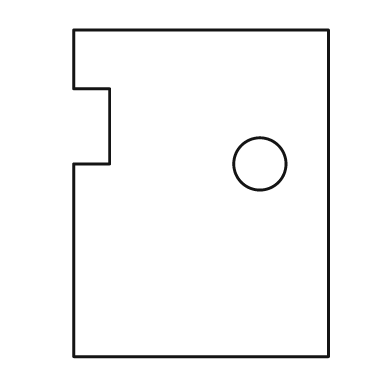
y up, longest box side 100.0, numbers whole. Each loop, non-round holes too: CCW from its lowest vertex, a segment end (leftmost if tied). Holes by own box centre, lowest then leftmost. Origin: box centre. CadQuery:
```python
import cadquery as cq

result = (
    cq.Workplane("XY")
    .moveTo(-39.0, -50.0)
    .lineTo(39.0, -50.0)
    .lineTo(39.0, 50.0)
    .lineTo(-39.0, 50.0)
    .lineTo(-39.0, 32.0)
    .lineTo(-28.0, 32.0)
    .lineTo(-28.0, 9.0)
    .lineTo(-39.0, 9.0)
    .close()
    .moveTo(18.0, 9.0)
    .circle(8.0)
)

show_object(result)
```